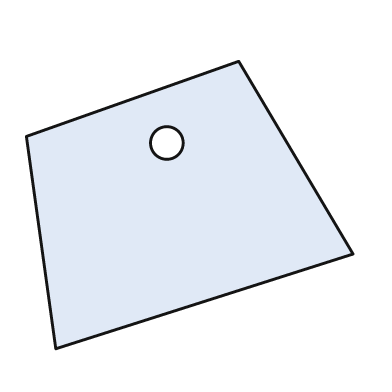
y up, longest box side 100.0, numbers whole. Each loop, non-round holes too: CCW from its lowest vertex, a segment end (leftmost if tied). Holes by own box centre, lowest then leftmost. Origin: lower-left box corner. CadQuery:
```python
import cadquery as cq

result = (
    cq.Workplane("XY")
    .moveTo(9.0, 0.0)
    .lineTo(100.0, 29.0)
    .lineTo(65.0, 88.0)
    .lineTo(0.0, 65.0)
    .close()
    .moveTo(43.0, 63.0)
    .circle(5.0)
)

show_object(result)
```